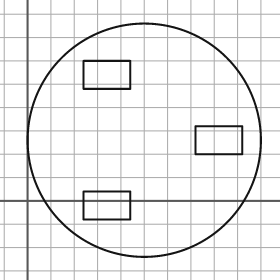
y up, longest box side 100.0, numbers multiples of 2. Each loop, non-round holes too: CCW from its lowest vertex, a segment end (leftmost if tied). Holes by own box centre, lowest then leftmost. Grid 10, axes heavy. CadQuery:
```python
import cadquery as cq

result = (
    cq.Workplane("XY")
    .moveTo(50.0, 26.0)
    .circle(50.0)
    .moveTo(24.0, -8.0)
    .lineTo(44.0, -8.0)
    .lineTo(44.0, 4.0)
    .lineTo(24.0, 4.0)
    .close()
    .moveTo(72.0, 20.0)
    .lineTo(92.0, 20.0)
    .lineTo(92.0, 32.0)
    .lineTo(72.0, 32.0)
    .close()
    .moveTo(24.0, 48.0)
    .lineTo(44.0, 48.0)
    .lineTo(44.0, 60.0)
    .lineTo(24.0, 60.0)
    .close()
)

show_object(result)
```